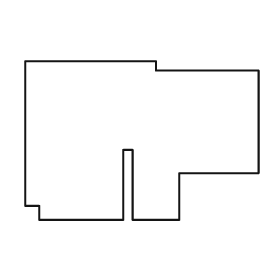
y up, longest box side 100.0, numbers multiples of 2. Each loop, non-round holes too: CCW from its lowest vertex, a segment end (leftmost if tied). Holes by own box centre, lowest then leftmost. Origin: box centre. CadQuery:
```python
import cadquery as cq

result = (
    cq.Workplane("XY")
    .moveTo(-44.0, -34.0)
    .lineTo(-8.0, -34.0)
    .lineTo(-8.0, -4.0)
    .lineTo(-4.0, -4.0)
    .lineTo(-4.0, -34.0)
    .lineTo(16.0, -34.0)
    .lineTo(16.0, -14.0)
    .lineTo(50.0, -14.0)
    .lineTo(50.0, 30.0)
    .lineTo(6.0, 30.0)
    .lineTo(6.0, 34.0)
    .lineTo(-50.0, 34.0)
    .lineTo(-50.0, -28.0)
    .lineTo(-44.0, -28.0)
    .close()
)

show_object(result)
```